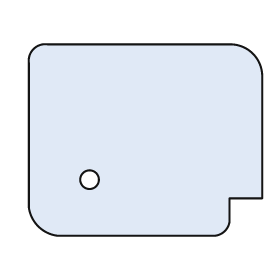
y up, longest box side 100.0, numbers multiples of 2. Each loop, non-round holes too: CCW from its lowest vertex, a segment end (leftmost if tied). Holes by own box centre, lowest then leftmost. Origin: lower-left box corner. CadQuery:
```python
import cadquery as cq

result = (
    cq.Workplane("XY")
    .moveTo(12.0, 0.0)
    .lineTo(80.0, 0.0)
    .threePointArc((84.0, 2.0), (86.0, 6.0))
    .lineTo(86.0, 16.0)
    .lineTo(100.0, 16.0)
    .lineTo(100.0, 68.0)
    .threePointArc((96.0, 78.0), (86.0, 82.0))
    .lineTo(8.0, 82.0)
    .threePointArc((2.0, 80.0), (0.0, 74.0))
    .lineTo(0.0, 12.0)
    .threePointArc((4.0, 4.0), (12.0, 0.0))
    .close()
    .moveTo(26.0, 24.0)
    .circle(4.0)
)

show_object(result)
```